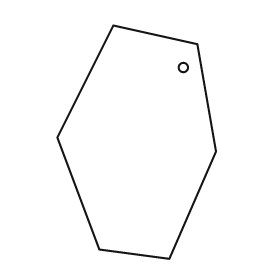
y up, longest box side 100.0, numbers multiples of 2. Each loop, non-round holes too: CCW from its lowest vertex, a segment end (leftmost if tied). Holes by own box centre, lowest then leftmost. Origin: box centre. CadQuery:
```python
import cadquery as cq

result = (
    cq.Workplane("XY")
    .moveTo(14.0, -50.0)
    .lineTo(34.0, -4.0)
    .lineTo(26.0, 42.0)
    .lineTo(-10.0, 50.0)
    .lineTo(-34.0, 2.0)
    .lineTo(-16.0, -46.0)
    .close()
    .moveTo(20.0, 32.0)
    .circle(2.0)
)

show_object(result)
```